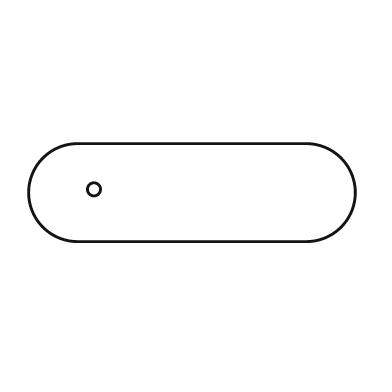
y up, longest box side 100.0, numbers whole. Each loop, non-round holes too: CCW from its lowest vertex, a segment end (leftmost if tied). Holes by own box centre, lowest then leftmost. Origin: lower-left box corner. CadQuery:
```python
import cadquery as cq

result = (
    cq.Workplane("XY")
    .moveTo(15.0, 0.0)
    .lineTo(85.0, 0.0)
    .threePointArc((100.0, 15.0), (85.0, 30.0))
    .lineTo(15.0, 30.0)
    .threePointArc((0.0, 15.0), (15.0, 0.0))
    .close()
    .moveTo(20.0, 16.0)
    .circle(2.0)
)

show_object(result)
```